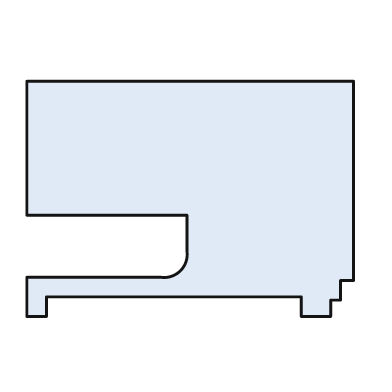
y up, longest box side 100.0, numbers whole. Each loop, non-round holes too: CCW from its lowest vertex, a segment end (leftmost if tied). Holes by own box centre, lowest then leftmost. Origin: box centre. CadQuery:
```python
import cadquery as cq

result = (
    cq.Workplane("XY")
    .moveTo(-50.0, -36.0)
    .lineTo(-44.0, -36.0)
    .lineTo(-44.0, -30.0)
    .lineTo(34.0, -30.0)
    .lineTo(34.0, -36.0)
    .lineTo(43.0, -36.0)
    .lineTo(43.0, -31.0)
    .lineTo(46.0, -31.0)
    .lineTo(46.0, -25.0)
    .lineTo(50.0, -25.0)
    .lineTo(50.0, 36.0)
    .lineTo(-50.0, 36.0)
    .lineTo(-50.0, -5.0)
    .lineTo(-1.0, -5.0)
    .lineTo(-1.0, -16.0)
    .threePointArc((-3.0, -22.0), (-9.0, -24.0))
    .lineTo(-50.0, -24.0)
    .close()
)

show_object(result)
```